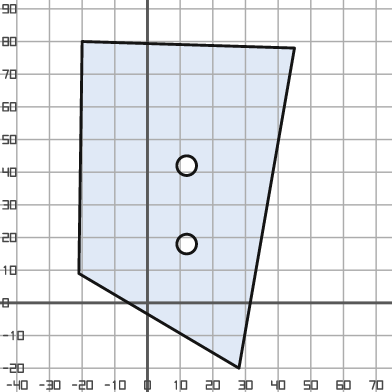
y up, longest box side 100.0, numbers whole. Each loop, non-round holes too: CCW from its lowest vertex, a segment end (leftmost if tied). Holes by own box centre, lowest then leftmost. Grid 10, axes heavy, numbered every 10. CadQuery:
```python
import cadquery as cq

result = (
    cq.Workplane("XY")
    .moveTo(28.0, -20.0)
    .lineTo(45.0, 78.0)
    .lineTo(-20.0, 80.0)
    .lineTo(-21.0, 9.0)
    .close()
    .moveTo(12.0, 18.0)
    .circle(3.0)
    .moveTo(12.0, 42.0)
    .circle(3.0)
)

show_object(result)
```